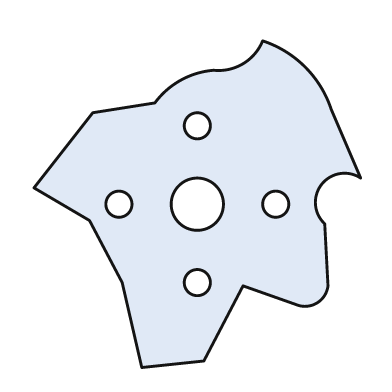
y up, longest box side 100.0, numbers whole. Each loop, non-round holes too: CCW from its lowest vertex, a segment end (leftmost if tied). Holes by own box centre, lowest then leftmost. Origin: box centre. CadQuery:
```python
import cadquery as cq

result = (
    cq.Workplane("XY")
    .moveTo(-17.0, -50.0)
    .lineTo(2.0, -48.0)
    .lineTo(14.0, -25.0)
    .lineTo(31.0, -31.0)
    .threePointArc((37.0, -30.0), (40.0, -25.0))
    .lineTo(39.0, -6.0)
    .threePointArc((38.0, 6.0), (50.0, 8.0))
    .lineTo(41.0, 29.0)
    .threePointArc((33.0, 42.0), (20.0, 50.0))
    .threePointArc((14.0, 43.0), (5.0, 41.0))
    .threePointArc((-5.0, 38.0), (-13.0, 31.0))
    .lineTo(-32.0, 28.0)
    .lineTo(-50.0, 5.0)
    .lineTo(-33.0, -5.0)
    .lineTo(-23.0, -24.0)
    .close()
    .moveTo(0.0, -24.0)
    .circle(4.0)
    .moveTo(-24.0, 0.0)
    .circle(4.0)
    .moveTo(0.0, 0.0)
    .circle(8.0)
    .moveTo(24.0, 0.0)
    .circle(4.0)
    .moveTo(0.0, 24.0)
    .circle(4.0)
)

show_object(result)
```